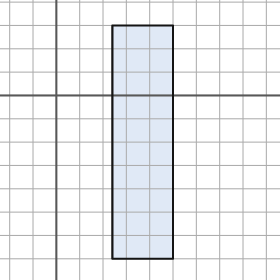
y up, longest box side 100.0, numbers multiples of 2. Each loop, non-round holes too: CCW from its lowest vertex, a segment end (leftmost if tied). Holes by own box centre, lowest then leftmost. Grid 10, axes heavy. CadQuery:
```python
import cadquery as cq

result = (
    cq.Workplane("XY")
    .moveTo(24.0, -70.0)
    .lineTo(50.0, -70.0)
    .lineTo(50.0, 30.0)
    .lineTo(24.0, 30.0)
    .close()
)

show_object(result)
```